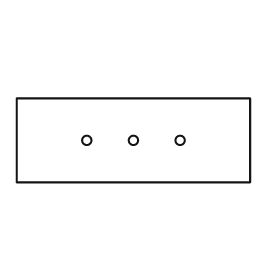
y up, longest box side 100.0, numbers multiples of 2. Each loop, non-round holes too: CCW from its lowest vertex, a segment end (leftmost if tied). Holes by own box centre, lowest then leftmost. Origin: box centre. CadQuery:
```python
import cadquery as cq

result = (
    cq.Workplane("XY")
    .moveTo(-50.0, -18.0)
    .lineTo(50.0, -18.0)
    .lineTo(50.0, 18.0)
    .lineTo(-50.0, 18.0)
    .close()
    .moveTo(-20.0, 0.0)
    .circle(2.0)
    .moveTo(0.0, 0.0)
    .circle(2.0)
    .moveTo(20.0, 0.0)
    .circle(2.0)
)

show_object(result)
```